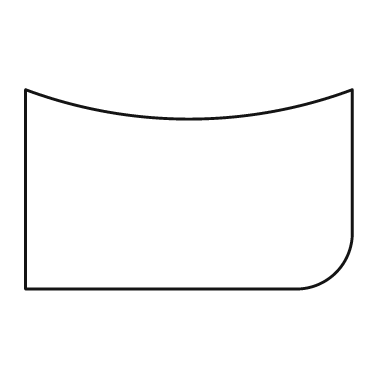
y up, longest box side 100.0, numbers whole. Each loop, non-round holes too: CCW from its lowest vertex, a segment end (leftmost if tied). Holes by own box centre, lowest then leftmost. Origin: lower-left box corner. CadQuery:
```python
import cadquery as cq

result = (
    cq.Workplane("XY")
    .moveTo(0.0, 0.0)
    .lineTo(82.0, 0.0)
    .threePointArc((95.0, 5.0), (100.0, 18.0))
    .lineTo(100.0, 61.0)
    .threePointArc((50.0, 52.0), (0.0, 61.0))
    .close()
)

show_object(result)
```